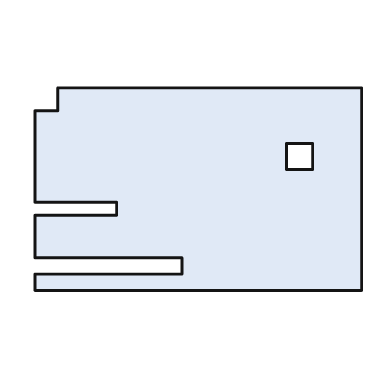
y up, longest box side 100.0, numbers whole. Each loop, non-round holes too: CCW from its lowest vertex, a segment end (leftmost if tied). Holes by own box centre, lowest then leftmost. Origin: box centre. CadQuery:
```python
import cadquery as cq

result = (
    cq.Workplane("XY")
    .moveTo(-50.0, -31.0)
    .lineTo(50.0, -31.0)
    .lineTo(50.0, 31.0)
    .lineTo(-43.0, 31.0)
    .lineTo(-43.0, 24.0)
    .lineTo(-50.0, 24.0)
    .lineTo(-50.0, -4.0)
    .lineTo(-25.0, -4.0)
    .lineTo(-25.0, -8.0)
    .lineTo(-50.0, -8.0)
    .lineTo(-50.0, -21.0)
    .lineTo(-5.0, -21.0)
    .lineTo(-5.0, -26.0)
    .lineTo(-50.0, -26.0)
    .close()
    .moveTo(27.0, 6.0)
    .lineTo(35.0, 6.0)
    .lineTo(35.0, 14.0)
    .lineTo(27.0, 14.0)
    .close()
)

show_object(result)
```